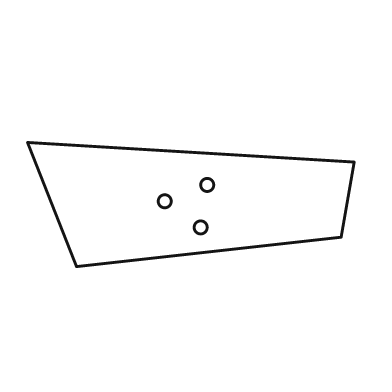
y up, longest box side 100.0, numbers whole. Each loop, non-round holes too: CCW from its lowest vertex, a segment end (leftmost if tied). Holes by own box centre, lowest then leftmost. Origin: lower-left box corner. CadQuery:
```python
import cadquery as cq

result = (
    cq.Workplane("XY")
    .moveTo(15.0, 0.0)
    .lineTo(96.0, 9.0)
    .lineTo(100.0, 32.0)
    .lineTo(0.0, 38.0)
    .close()
    .moveTo(53.0, 12.0)
    .circle(2.0)
    .moveTo(42.0, 20.0)
    .circle(2.0)
    .moveTo(55.0, 25.0)
    .circle(2.0)
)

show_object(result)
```